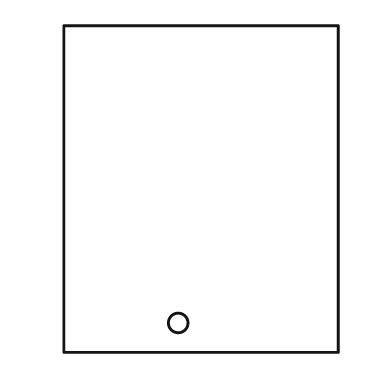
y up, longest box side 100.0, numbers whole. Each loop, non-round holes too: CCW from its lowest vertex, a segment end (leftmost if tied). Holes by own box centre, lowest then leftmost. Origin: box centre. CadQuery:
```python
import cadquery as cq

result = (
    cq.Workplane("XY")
    .moveTo(-42.0, -50.0)
    .lineTo(42.0, -50.0)
    .lineTo(42.0, 50.0)
    .lineTo(-42.0, 50.0)
    .close()
    .moveTo(-7.0, -41.0)
    .circle(3.0)
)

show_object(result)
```